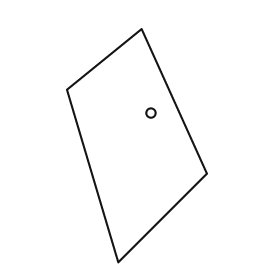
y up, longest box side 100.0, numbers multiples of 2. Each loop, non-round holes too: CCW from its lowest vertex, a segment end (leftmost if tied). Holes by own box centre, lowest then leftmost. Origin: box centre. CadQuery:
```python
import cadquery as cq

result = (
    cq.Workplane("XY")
    .moveTo(-8.0, -50.0)
    .lineTo(30.0, -12.0)
    .lineTo(2.0, 50.0)
    .lineTo(-30.0, 24.0)
    .close()
    .moveTo(6.0, 14.0)
    .circle(2.0)
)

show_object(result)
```